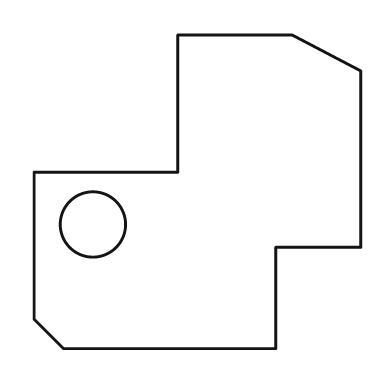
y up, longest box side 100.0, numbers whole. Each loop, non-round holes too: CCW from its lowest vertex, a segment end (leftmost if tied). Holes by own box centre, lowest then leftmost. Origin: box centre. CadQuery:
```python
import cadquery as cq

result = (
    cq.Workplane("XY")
    .moveTo(-41.0, -48.0)
    .lineTo(24.0, -48.0)
    .lineTo(24.0, -17.0)
    .lineTo(50.0, -17.0)
    .lineTo(50.0, 37.0)
    .lineTo(29.0, 48.0)
    .lineTo(-6.0, 48.0)
    .lineTo(-6.0, 6.0)
    .lineTo(-50.0, 6.0)
    .lineTo(-50.0, -39.0)
    .close()
    .moveTo(-32.0, -10.0)
    .circle(10.0)
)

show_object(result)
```